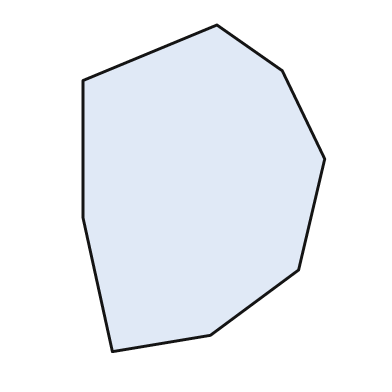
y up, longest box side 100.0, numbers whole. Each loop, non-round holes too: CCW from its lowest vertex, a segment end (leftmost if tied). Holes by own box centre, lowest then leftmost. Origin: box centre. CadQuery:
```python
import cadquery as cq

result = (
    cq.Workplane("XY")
    .moveTo(-28.0, -50.0)
    .lineTo(2.0, -45.0)
    .lineTo(29.0, -25.0)
    .lineTo(37.0, 9.0)
    .lineTo(24.0, 36.0)
    .lineTo(4.0, 50.0)
    .lineTo(-37.0, 33.0)
    .lineTo(-37.0, -9.0)
    .close()
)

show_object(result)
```